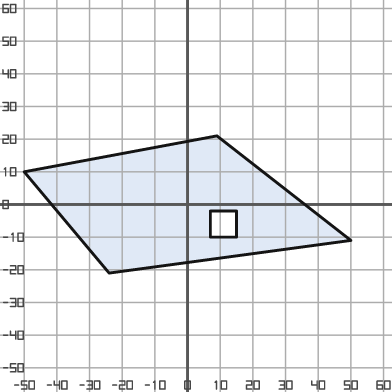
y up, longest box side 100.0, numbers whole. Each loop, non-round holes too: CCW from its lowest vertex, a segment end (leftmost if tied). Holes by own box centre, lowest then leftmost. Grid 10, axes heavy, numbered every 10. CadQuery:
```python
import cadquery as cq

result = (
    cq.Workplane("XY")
    .moveTo(-24.0, -21.0)
    .lineTo(50.0, -11.0)
    .lineTo(9.0, 21.0)
    .lineTo(-50.0, 10.0)
    .close()
    .moveTo(7.0, -10.0)
    .lineTo(15.0, -10.0)
    .lineTo(15.0, -2.0)
    .lineTo(7.0, -2.0)
    .close()
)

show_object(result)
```